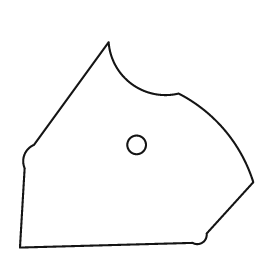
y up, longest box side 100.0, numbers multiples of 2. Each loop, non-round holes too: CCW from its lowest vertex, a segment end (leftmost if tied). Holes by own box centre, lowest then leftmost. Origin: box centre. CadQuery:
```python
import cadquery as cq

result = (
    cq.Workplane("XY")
    .moveTo(-50.0, -44.0)
    .lineTo(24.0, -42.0)
    .threePointArc((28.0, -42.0), (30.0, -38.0))
    .lineTo(50.0, -16.0)
    .threePointArc((38.0, 6.0), (18.0, 22.0))
    .threePointArc((-2.0, 26.0), (-12.0, 44.0))
    .lineTo(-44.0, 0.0)
    .threePointArc((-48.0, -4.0), (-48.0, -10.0))
    .close()
    .moveTo(0.0, 0.0)
    .circle(4.0)
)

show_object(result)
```